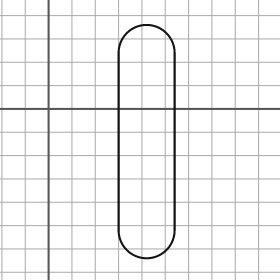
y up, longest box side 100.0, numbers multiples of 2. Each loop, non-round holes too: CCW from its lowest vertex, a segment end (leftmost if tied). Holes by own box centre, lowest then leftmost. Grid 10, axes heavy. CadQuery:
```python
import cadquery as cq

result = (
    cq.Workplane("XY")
    .moveTo(30.0, -52.0)
    .threePointArc((42.0, -64.0), (54.0, -52.0))
    .lineTo(54.0, 24.0)
    .threePointArc((42.0, 36.0), (30.0, 24.0))
    .close()
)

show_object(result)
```